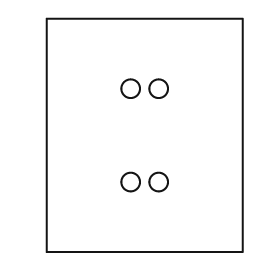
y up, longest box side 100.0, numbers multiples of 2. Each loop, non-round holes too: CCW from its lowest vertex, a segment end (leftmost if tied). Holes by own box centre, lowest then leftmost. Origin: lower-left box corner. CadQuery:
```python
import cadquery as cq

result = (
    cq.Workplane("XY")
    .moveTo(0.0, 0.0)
    .lineTo(84.0, 0.0)
    .lineTo(84.0, 100.0)
    .lineTo(0.0, 100.0)
    .close()
    .moveTo(36.0, 30.0)
    .circle(4.0)
    .moveTo(48.0, 30.0)
    .circle(4.0)
    .moveTo(36.0, 70.0)
    .circle(4.0)
    .moveTo(48.0, 70.0)
    .circle(4.0)
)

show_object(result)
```